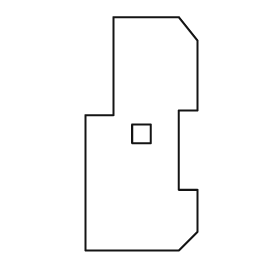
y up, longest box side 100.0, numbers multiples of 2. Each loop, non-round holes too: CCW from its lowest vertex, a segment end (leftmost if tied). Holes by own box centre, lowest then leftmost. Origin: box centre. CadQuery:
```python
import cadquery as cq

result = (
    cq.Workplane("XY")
    .moveTo(-24.0, -50.0)
    .lineTo(16.0, -50.0)
    .lineTo(24.0, -42.0)
    .lineTo(24.0, -24.0)
    .lineTo(16.0, -24.0)
    .lineTo(16.0, 10.0)
    .lineTo(24.0, 10.0)
    .lineTo(24.0, 40.0)
    .lineTo(16.0, 50.0)
    .lineTo(-12.0, 50.0)
    .lineTo(-12.0, 8.0)
    .lineTo(-24.0, 8.0)
    .close()
    .moveTo(-4.0, -4.0)
    .lineTo(4.0, -4.0)
    .lineTo(4.0, 4.0)
    .lineTo(-4.0, 4.0)
    .close()
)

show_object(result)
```